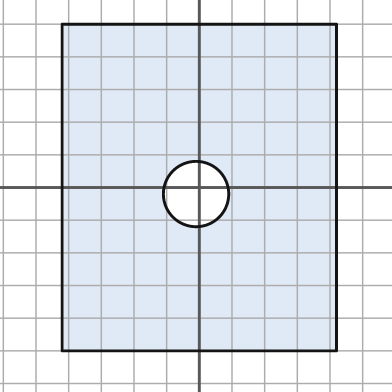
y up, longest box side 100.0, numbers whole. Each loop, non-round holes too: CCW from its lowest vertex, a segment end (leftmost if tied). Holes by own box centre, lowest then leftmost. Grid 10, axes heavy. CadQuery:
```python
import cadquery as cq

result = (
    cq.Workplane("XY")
    .moveTo(-42.0, -50.0)
    .lineTo(42.0, -50.0)
    .lineTo(42.0, 50.0)
    .lineTo(-42.0, 50.0)
    .close()
    .moveTo(-1.0, -2.0)
    .circle(10.0)
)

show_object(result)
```